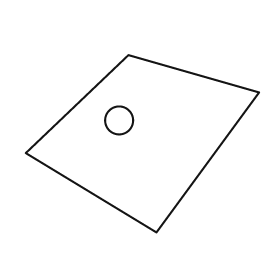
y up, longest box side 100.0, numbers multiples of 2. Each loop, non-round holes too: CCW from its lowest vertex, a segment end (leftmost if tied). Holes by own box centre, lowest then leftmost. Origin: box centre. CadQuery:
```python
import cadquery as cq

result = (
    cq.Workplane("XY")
    .moveTo(6.0, -38.0)
    .lineTo(50.0, 22.0)
    .lineTo(-6.0, 38.0)
    .lineTo(-50.0, -4.0)
    .close()
    .moveTo(-10.0, 10.0)
    .circle(6.0)
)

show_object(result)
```